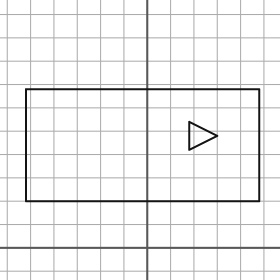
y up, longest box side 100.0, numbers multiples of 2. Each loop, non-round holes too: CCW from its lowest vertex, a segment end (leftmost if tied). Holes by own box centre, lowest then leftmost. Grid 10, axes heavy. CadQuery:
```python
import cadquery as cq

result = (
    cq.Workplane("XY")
    .moveTo(-52.0, 20.0)
    .lineTo(48.0, 20.0)
    .lineTo(48.0, 68.0)
    .lineTo(-52.0, 68.0)
    .close()
    .moveTo(18.0, 42.0)
    .lineTo(30.0, 48.0)
    .lineTo(18.0, 54.0)
    .close()
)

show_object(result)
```